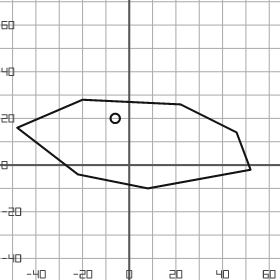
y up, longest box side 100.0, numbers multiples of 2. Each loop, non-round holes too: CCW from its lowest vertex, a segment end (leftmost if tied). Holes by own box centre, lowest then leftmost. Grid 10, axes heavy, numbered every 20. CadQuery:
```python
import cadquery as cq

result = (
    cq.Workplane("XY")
    .moveTo(8.0, -10.0)
    .lineTo(52.0, -2.0)
    .lineTo(46.0, 14.0)
    .lineTo(22.0, 26.0)
    .lineTo(-20.0, 28.0)
    .lineTo(-48.0, 16.0)
    .lineTo(-22.0, -4.0)
    .close()
    .moveTo(-6.0, 20.0)
    .circle(2.0)
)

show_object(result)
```